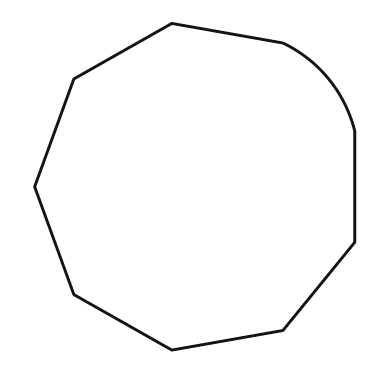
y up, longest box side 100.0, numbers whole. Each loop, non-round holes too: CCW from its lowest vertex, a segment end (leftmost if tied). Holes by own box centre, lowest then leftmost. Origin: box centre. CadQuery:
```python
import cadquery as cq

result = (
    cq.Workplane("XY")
    .moveTo(-7.0, -50.0)
    .lineTo(27.0, -44.0)
    .lineTo(49.0, -17.0)
    .lineTo(49.0, 17.0)
    .threePointArc((41.0, 33.0), (27.0, 44.0))
    .lineTo(-7.0, 50.0)
    .lineTo(-37.0, 33.0)
    .lineTo(-49.0, 0.0)
    .lineTo(-37.0, -33.0)
    .close()
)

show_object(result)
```